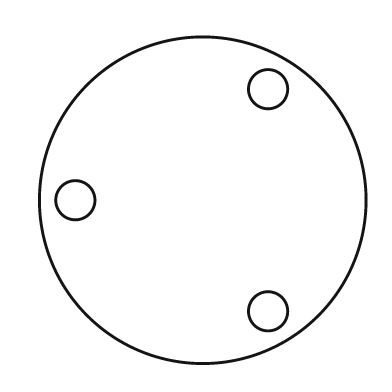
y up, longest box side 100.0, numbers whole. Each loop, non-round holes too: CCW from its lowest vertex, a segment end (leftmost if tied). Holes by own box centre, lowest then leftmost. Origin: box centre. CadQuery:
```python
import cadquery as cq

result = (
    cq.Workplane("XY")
    .moveTo(0.0, 0.0)
    .circle(50.0)
    .moveTo(20.0, -34.0)
    .circle(6.0)
    .moveTo(-39.0, 0.0)
    .circle(6.0)
    .moveTo(20.0, 34.0)
    .circle(6.0)
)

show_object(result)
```